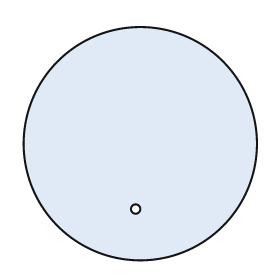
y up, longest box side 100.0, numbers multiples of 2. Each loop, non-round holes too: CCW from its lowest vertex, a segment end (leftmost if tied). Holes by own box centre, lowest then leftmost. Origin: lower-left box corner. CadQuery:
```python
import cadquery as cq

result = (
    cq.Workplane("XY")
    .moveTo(50.0, 50.0)
    .circle(50.0)
    .moveTo(48.0, 22.0)
    .circle(2.0)
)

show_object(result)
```